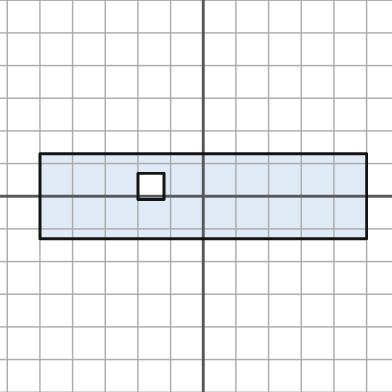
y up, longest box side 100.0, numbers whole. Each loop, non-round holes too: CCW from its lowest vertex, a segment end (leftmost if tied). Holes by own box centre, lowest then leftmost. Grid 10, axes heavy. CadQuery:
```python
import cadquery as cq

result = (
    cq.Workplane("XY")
    .moveTo(-50.0, -13.0)
    .lineTo(50.0, -13.0)
    .lineTo(50.0, 13.0)
    .lineTo(-50.0, 13.0)
    .close()
    .moveTo(-20.0, -1.0)
    .lineTo(-12.0, -1.0)
    .lineTo(-12.0, 7.0)
    .lineTo(-20.0, 7.0)
    .close()
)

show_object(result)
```